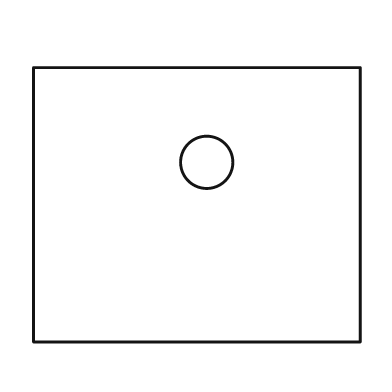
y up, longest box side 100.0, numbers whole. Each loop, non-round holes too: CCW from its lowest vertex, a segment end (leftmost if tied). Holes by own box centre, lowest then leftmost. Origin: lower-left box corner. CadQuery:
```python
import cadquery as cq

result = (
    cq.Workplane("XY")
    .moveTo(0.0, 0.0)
    .lineTo(100.0, 0.0)
    .lineTo(100.0, 84.0)
    .lineTo(0.0, 84.0)
    .close()
    .moveTo(53.0, 55.0)
    .circle(8.0)
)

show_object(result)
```